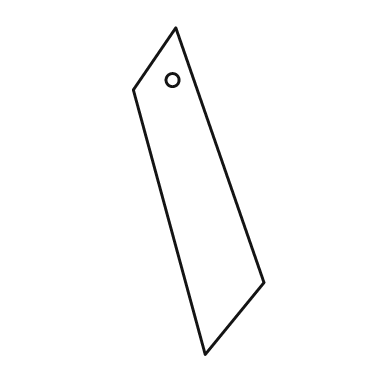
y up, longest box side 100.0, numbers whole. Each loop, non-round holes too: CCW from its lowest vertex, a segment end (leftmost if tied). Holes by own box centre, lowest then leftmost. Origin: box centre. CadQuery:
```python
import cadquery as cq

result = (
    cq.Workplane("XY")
    .moveTo(2.0, -50.0)
    .lineTo(20.0, -28.0)
    .lineTo(-7.0, 50.0)
    .lineTo(-20.0, 31.0)
    .close()
    .moveTo(-8.0, 34.0)
    .circle(2.0)
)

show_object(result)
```